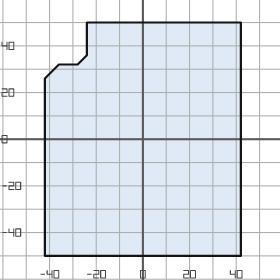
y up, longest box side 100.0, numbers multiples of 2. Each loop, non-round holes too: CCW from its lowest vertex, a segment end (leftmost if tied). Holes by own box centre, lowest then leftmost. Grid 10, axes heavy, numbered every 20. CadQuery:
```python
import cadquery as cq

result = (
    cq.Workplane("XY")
    .moveTo(-42.0, -50.0)
    .lineTo(42.0, -50.0)
    .lineTo(42.0, 50.0)
    .lineTo(-24.0, 50.0)
    .lineTo(-24.0, 36.0)
    .lineTo(-28.0, 32.0)
    .lineTo(-36.0, 32.0)
    .lineTo(-42.0, 26.0)
    .close()
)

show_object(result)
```